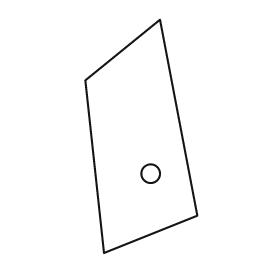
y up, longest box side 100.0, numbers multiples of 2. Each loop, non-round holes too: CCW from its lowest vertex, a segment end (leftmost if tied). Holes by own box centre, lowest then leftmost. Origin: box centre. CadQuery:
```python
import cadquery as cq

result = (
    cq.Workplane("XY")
    .moveTo(-16.0, -50.0)
    .lineTo(24.0, -34.0)
    .lineTo(8.0, 50.0)
    .lineTo(-24.0, 24.0)
    .close()
    .moveTo(4.0, -16.0)
    .circle(4.0)
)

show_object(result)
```